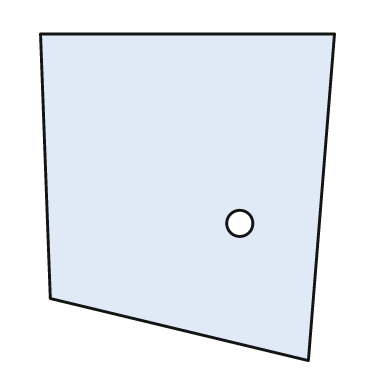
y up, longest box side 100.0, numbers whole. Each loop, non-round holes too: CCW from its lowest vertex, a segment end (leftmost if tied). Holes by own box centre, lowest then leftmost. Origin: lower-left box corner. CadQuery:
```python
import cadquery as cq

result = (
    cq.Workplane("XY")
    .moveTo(82.0, 0.0)
    .lineTo(90.0, 100.0)
    .lineTo(0.0, 100.0)
    .lineTo(3.0, 19.0)
    .close()
    .moveTo(61.0, 42.0)
    .circle(4.0)
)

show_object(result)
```